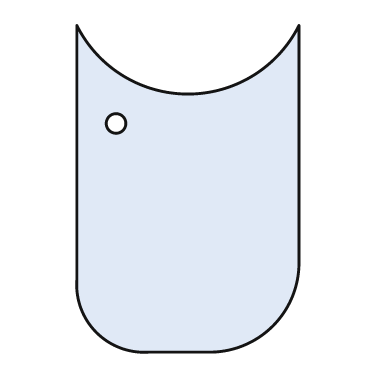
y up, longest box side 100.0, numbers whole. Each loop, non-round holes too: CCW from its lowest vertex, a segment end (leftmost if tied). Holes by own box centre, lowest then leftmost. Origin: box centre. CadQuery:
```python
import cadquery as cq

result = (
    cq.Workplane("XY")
    .moveTo(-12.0, -50.0)
    .lineTo(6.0, -50.0)
    .threePointArc((26.0, -42.0), (34.0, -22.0))
    .lineTo(34.0, 50.0)
    .threePointArc((0.0, 29.0), (-34.0, 50.0))
    .lineTo(-34.0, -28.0)
    .threePointArc((-28.0, -44.0), (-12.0, -50.0))
    .close()
    .moveTo(-22.0, 20.0)
    .circle(3.0)
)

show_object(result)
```